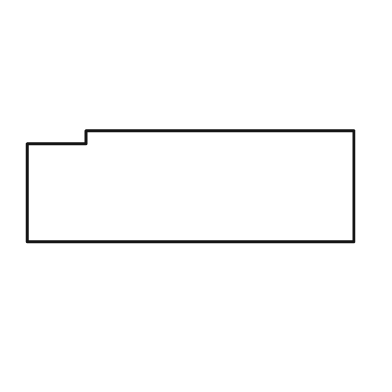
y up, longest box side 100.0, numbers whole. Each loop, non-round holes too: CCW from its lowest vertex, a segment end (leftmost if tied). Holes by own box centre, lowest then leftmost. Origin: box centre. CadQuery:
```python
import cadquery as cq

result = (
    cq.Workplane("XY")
    .moveTo(-50.0, -17.0)
    .lineTo(50.0, -17.0)
    .lineTo(50.0, 17.0)
    .lineTo(-32.0, 17.0)
    .lineTo(-32.0, 13.0)
    .lineTo(-50.0, 13.0)
    .close()
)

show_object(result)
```